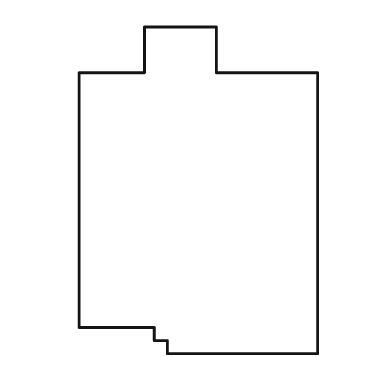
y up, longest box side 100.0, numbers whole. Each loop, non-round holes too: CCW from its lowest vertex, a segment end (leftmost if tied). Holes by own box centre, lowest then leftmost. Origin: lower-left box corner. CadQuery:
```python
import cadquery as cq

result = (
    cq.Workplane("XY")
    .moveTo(27.0, 0.0)
    .lineTo(73.0, 0.0)
    .lineTo(73.0, 86.0)
    .lineTo(42.0, 86.0)
    .lineTo(42.0, 100.0)
    .lineTo(20.0, 100.0)
    .lineTo(20.0, 86.0)
    .lineTo(0.0, 86.0)
    .lineTo(0.0, 8.0)
    .lineTo(23.0, 8.0)
    .lineTo(23.0, 4.0)
    .lineTo(27.0, 4.0)
    .close()
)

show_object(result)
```